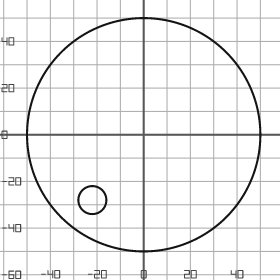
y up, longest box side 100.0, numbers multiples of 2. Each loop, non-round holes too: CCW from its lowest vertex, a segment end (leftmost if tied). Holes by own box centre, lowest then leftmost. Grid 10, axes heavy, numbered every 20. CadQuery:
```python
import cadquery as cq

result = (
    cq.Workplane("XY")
    .moveTo(0.0, 0.0)
    .circle(50.0)
    .moveTo(-22.0, -28.0)
    .circle(6.0)
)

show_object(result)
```